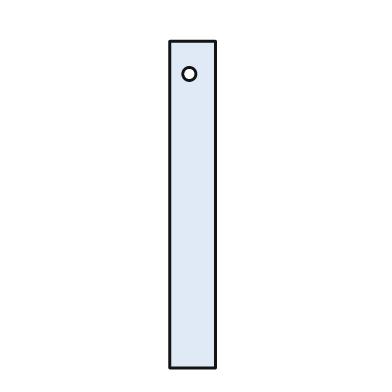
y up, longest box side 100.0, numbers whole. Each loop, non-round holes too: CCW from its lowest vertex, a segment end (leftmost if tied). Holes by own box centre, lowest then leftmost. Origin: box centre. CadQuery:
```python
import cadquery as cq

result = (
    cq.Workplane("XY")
    .moveTo(-7.0, -50.0)
    .lineTo(7.0, -50.0)
    .lineTo(7.0, 50.0)
    .lineTo(-7.0, 50.0)
    .close()
    .moveTo(-1.0, 40.0)
    .circle(2.0)
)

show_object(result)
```